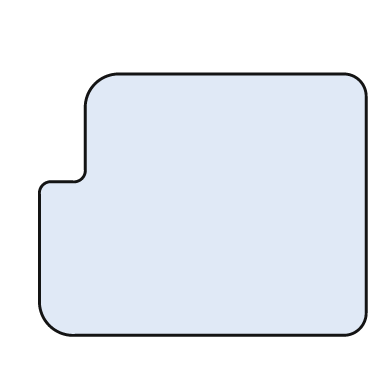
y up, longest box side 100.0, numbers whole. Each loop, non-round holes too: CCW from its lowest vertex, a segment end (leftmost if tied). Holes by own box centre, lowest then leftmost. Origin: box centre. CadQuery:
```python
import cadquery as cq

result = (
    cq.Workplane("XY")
    .moveTo(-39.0, -40.0)
    .lineTo(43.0, -40.0)
    .threePointArc((48.0, -38.0), (50.0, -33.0))
    .lineTo(50.0, 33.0)
    .threePointArc((48.0, 38.0), (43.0, 40.0))
    .lineTo(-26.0, 40.0)
    .threePointArc((-33.0, 37.0), (-36.0, 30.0))
    .lineTo(-36.0, 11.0)
    .threePointArc((-37.0, 8.0), (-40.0, 7.0))
    .lineTo(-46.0, 7.0)
    .threePointArc((-49.0, 6.0), (-50.0, 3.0))
    .lineTo(-50.0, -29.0)
    .threePointArc((-47.0, -37.0), (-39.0, -40.0))
    .close()
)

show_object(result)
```